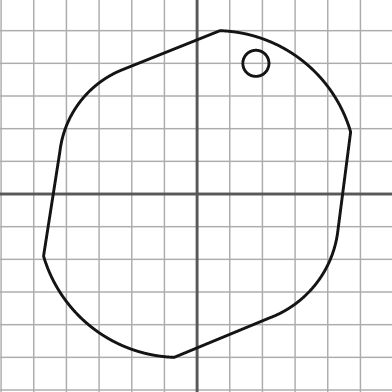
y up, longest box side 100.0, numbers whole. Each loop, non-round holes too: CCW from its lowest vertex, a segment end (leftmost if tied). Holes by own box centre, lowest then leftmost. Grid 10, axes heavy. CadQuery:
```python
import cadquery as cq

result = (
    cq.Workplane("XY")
    .moveTo(-7.0, -50.0)
    .lineTo(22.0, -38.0)
    .threePointArc((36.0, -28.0), (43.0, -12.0))
    .lineTo(47.0, 19.0)
    .threePointArc((32.0, 41.0), (7.0, 50.0))
    .lineTo(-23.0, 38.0)
    .threePointArc((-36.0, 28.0), (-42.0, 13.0))
    .lineTo(-47.0, -19.0)
    .threePointArc((-32.0, -41.0), (-7.0, -50.0))
    .close()
    .moveTo(18.0, 40.0)
    .circle(4.0)
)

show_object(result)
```